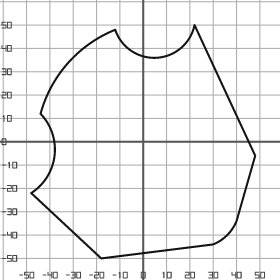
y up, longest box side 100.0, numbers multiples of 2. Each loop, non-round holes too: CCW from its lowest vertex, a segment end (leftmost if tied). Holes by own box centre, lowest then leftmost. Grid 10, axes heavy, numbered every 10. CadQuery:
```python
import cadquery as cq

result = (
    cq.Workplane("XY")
    .moveTo(-18.0, -50.0)
    .lineTo(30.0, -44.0)
    .threePointArc((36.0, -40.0), (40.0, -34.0))
    .lineTo(48.0, -6.0)
    .lineTo(22.0, 50.0)
    .threePointArc((6.0, 36.0), (-12.0, 48.0))
    .threePointArc((-32.0, 34.0), (-44.0, 12.0))
    .threePointArc((-38.0, -6.0), (-48.0, -22.0))
    .close()
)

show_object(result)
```